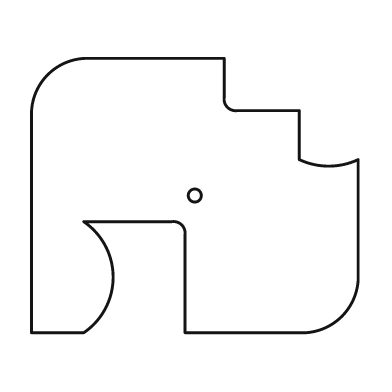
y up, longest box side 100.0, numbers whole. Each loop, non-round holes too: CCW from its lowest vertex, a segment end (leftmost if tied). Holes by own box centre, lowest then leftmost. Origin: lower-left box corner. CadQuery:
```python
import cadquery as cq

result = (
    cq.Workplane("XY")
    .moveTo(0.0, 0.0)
    .lineTo(16.0, 0.0)
    .threePointArc((25.0, 17.0), (16.0, 34.0))
    .lineTo(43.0, 34.0)
    .threePointArc((46.0, 33.0), (47.0, 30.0))
    .lineTo(47.0, 0.0)
    .lineTo(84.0, 0.0)
    .threePointArc((95.0, 5.0), (100.0, 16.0))
    .lineTo(100.0, 53.0)
    .threePointArc((91.0, 51.0), (82.0, 53.0))
    .lineTo(82.0, 68.0)
    .lineTo(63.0, 68.0)
    .threePointArc((60.0, 69.0), (59.0, 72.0))
    .lineTo(59.0, 84.0)
    .lineTo(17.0, 84.0)
    .threePointArc((5.0, 79.0), (0.0, 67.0))
    .close()
    .moveTo(50.0, 42.0)
    .circle(2.0)
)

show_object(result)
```